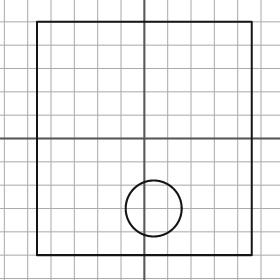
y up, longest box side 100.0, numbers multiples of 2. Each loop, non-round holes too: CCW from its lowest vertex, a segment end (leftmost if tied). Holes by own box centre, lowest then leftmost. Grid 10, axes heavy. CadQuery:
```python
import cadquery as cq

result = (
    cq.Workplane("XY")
    .moveTo(-46.0, -50.0)
    .lineTo(46.0, -50.0)
    .lineTo(46.0, 50.0)
    .lineTo(-46.0, 50.0)
    .close()
    .moveTo(4.0, -30.0)
    .circle(12.0)
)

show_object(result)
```